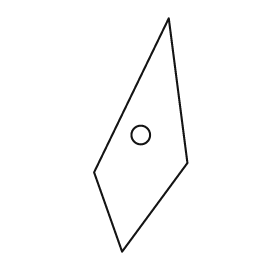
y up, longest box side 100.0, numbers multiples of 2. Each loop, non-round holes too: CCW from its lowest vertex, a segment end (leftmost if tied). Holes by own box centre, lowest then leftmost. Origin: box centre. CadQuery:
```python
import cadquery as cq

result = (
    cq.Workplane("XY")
    .moveTo(-8.0, -50.0)
    .lineTo(20.0, -12.0)
    .lineTo(12.0, 50.0)
    .lineTo(-20.0, -16.0)
    .close()
    .moveTo(0.0, 0.0)
    .circle(4.0)
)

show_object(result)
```